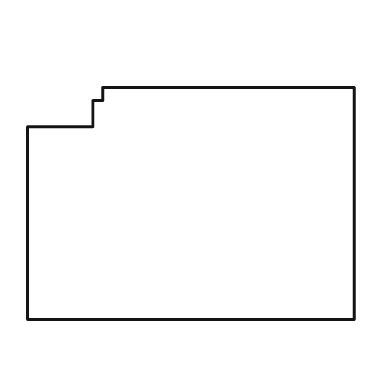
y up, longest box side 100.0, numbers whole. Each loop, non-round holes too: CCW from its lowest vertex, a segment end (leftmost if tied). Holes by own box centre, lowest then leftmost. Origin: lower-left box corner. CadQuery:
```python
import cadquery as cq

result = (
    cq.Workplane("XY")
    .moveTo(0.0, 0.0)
    .lineTo(100.0, 0.0)
    .lineTo(100.0, 71.0)
    .lineTo(23.0, 71.0)
    .lineTo(23.0, 67.0)
    .lineTo(20.0, 67.0)
    .lineTo(20.0, 59.0)
    .lineTo(0.0, 59.0)
    .close()
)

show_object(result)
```